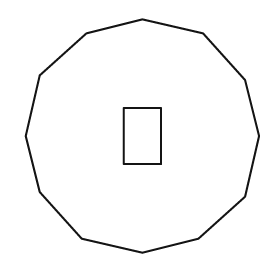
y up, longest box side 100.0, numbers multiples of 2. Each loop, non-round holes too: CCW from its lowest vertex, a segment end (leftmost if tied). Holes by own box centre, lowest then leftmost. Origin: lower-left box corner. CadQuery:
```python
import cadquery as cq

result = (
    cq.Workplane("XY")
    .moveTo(50.0, 0.0)
    .lineTo(74.0, 6.0)
    .lineTo(94.0, 24.0)
    .lineTo(100.0, 50.0)
    .lineTo(94.0, 74.0)
    .lineTo(76.0, 94.0)
    .lineTo(50.0, 100.0)
    .lineTo(26.0, 94.0)
    .lineTo(6.0, 76.0)
    .lineTo(0.0, 50.0)
    .lineTo(6.0, 26.0)
    .lineTo(24.0, 6.0)
    .close()
    .moveTo(42.0, 38.0)
    .lineTo(58.0, 38.0)
    .lineTo(58.0, 62.0)
    .lineTo(42.0, 62.0)
    .close()
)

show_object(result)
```